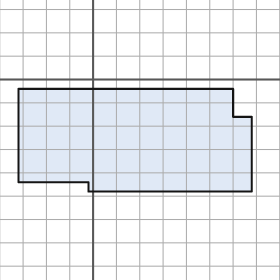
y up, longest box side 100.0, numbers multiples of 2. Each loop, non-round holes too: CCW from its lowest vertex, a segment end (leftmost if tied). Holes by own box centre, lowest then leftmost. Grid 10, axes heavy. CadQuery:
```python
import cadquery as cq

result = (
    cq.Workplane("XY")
    .moveTo(-2.0, -48.0)
    .lineTo(68.0, -48.0)
    .lineTo(68.0, -16.0)
    .lineTo(60.0, -16.0)
    .lineTo(60.0, -4.0)
    .lineTo(-32.0, -4.0)
    .lineTo(-32.0, -44.0)
    .lineTo(-2.0, -44.0)
    .close()
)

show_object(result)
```